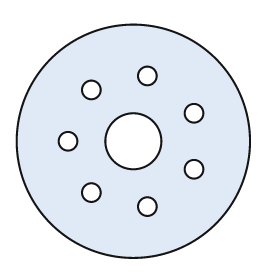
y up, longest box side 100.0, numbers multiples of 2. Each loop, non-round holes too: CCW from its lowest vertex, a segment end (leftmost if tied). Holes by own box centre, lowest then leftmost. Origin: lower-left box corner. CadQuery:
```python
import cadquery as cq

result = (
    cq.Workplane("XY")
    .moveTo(50.0, 50.0)
    .circle(50.0)
    .moveTo(56.0, 22.0)
    .circle(4.0)
    .moveTo(32.0, 28.0)
    .circle(4.0)
    .moveTo(76.0, 38.0)
    .circle(4.0)
    .moveTo(22.0, 50.0)
    .circle(4.0)
    .moveTo(50.0, 50.0)
    .circle(12.0)
    .moveTo(76.0, 62.0)
    .circle(4.0)
    .moveTo(32.0, 72.0)
    .circle(4.0)
    .moveTo(56.0, 78.0)
    .circle(4.0)
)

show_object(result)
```